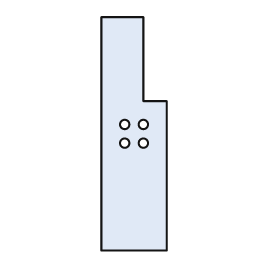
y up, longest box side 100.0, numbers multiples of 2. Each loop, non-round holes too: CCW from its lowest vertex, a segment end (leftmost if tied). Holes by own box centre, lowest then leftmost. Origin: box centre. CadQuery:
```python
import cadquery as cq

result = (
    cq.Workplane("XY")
    .moveTo(-14.0, -50.0)
    .lineTo(14.0, -50.0)
    .lineTo(14.0, 14.0)
    .lineTo(4.0, 14.0)
    .lineTo(4.0, 50.0)
    .lineTo(-14.0, 50.0)
    .close()
    .moveTo(-4.0, -4.0)
    .circle(2.0)
    .moveTo(4.0, -4.0)
    .circle(2.0)
    .moveTo(-4.0, 4.0)
    .circle(2.0)
    .moveTo(4.0, 4.0)
    .circle(2.0)
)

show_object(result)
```